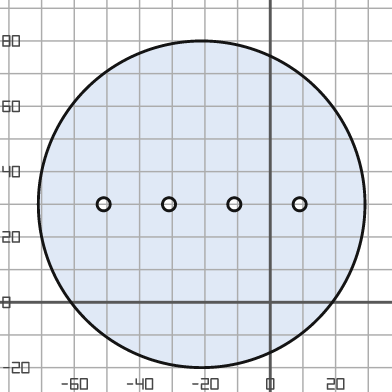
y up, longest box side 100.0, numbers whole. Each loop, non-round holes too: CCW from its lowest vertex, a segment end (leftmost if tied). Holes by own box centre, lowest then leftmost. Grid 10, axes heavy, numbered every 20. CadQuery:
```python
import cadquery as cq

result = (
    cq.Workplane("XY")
    .moveTo(-21.0, 30.0)
    .circle(50.0)
    .moveTo(-51.0, 30.0)
    .circle(2.0)
    .moveTo(-31.0, 30.0)
    .circle(2.0)
    .moveTo(-11.0, 30.0)
    .circle(2.0)
    .moveTo(9.0, 30.0)
    .circle(2.0)
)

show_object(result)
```